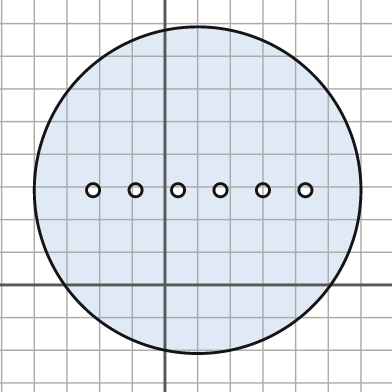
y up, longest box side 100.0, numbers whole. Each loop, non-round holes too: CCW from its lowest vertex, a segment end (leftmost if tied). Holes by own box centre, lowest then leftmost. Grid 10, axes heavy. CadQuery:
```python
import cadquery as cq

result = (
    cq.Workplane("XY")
    .moveTo(10.0, 29.0)
    .circle(50.0)
    .moveTo(-22.0, 29.0)
    .circle(2.0)
    .moveTo(-9.0, 29.0)
    .circle(2.0)
    .moveTo(4.0, 29.0)
    .circle(2.0)
    .moveTo(17.0, 29.0)
    .circle(2.0)
    .moveTo(30.0, 29.0)
    .circle(2.0)
    .moveTo(43.0, 29.0)
    .circle(2.0)
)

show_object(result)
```